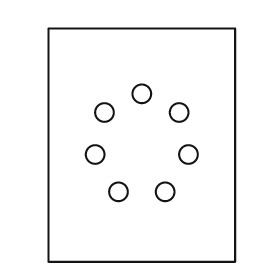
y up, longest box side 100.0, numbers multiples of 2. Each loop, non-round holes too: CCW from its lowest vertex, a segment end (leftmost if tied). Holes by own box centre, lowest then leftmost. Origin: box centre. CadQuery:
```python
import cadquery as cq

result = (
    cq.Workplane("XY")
    .moveTo(-40.0, -50.0)
    .lineTo(40.0, -50.0)
    .lineTo(40.0, 50.0)
    .lineTo(-40.0, 50.0)
    .close()
    .moveTo(-10.0, -20.0)
    .circle(4.0)
    .moveTo(10.0, -20.0)
    .circle(4.0)
    .moveTo(-20.0, -4.0)
    .circle(4.0)
    .moveTo(20.0, -4.0)
    .circle(4.0)
    .moveTo(-16.0, 14.0)
    .circle(4.0)
    .moveTo(16.0, 14.0)
    .circle(4.0)
    .moveTo(0.0, 22.0)
    .circle(4.0)
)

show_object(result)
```